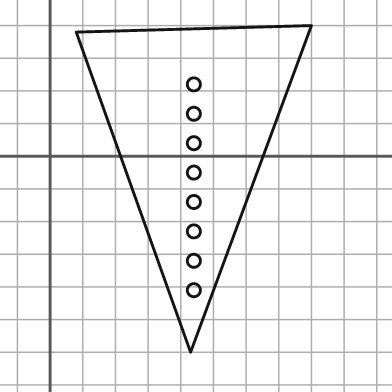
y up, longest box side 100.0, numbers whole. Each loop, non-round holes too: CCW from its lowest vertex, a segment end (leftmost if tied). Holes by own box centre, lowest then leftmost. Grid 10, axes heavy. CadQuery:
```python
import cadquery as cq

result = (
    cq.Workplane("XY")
    .moveTo(43.0, -60.0)
    .lineTo(80.0, 40.0)
    .lineTo(8.0, 38.0)
    .close()
    .moveTo(44.0, -41.0)
    .circle(2.0)
    .moveTo(44.0, -32.0)
    .circle(2.0)
    .moveTo(44.0, -23.0)
    .circle(2.0)
    .moveTo(44.0, -14.0)
    .circle(2.0)
    .moveTo(44.0, -5.0)
    .circle(2.0)
    .moveTo(44.0, 4.0)
    .circle(2.0)
    .moveTo(44.0, 13.0)
    .circle(2.0)
    .moveTo(44.0, 22.0)
    .circle(2.0)
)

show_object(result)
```